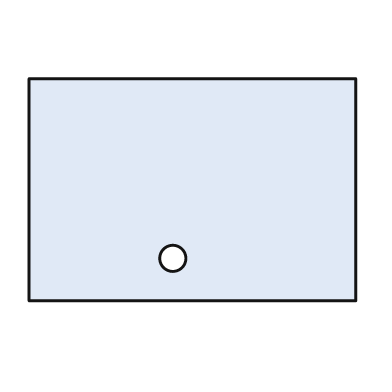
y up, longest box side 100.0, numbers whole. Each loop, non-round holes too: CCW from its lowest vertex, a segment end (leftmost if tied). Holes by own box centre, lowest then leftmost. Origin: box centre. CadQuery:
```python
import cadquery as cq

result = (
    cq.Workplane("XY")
    .moveTo(-50.0, -34.0)
    .lineTo(50.0, -34.0)
    .lineTo(50.0, 34.0)
    .lineTo(-50.0, 34.0)
    .close()
    .moveTo(-6.0, -21.0)
    .circle(4.0)
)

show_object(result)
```